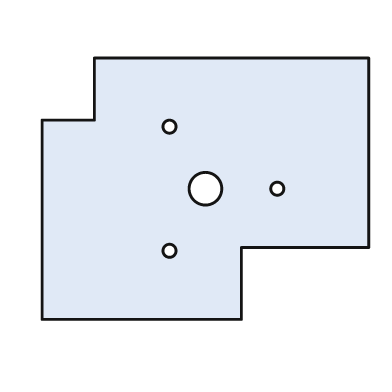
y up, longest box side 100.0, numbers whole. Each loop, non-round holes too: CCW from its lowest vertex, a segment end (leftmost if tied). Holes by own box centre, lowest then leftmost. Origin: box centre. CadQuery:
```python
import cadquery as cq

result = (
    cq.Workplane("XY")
    .moveTo(-50.0, -40.0)
    .lineTo(11.0, -40.0)
    .lineTo(11.0, -18.0)
    .lineTo(50.0, -18.0)
    .lineTo(50.0, 40.0)
    .lineTo(-34.0, 40.0)
    .lineTo(-34.0, 21.0)
    .lineTo(-50.0, 21.0)
    .close()
    .moveTo(-11.0, -19.0)
    .circle(2.0)
    .moveTo(0.0, 0.0)
    .circle(5.0)
    .moveTo(22.0, 0.0)
    .circle(2.0)
    .moveTo(-11.0, 19.0)
    .circle(2.0)
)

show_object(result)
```